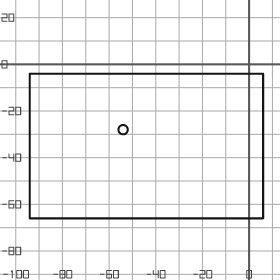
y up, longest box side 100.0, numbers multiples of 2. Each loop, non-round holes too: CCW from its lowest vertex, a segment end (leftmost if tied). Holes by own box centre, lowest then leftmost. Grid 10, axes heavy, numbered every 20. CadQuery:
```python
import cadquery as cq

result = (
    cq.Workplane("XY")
    .moveTo(-94.0, -66.0)
    .lineTo(6.0, -66.0)
    .lineTo(6.0, -4.0)
    .lineTo(-94.0, -4.0)
    .close()
    .moveTo(-54.0, -28.0)
    .circle(2.0)
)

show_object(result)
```